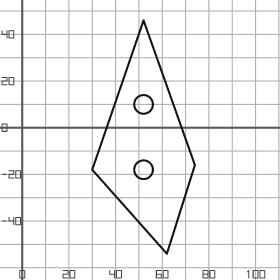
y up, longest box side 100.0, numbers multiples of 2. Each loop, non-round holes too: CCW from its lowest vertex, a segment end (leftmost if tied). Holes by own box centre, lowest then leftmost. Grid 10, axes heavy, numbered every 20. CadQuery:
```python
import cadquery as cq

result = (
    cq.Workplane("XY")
    .moveTo(62.0, -54.0)
    .lineTo(74.0, -16.0)
    .lineTo(52.0, 46.0)
    .lineTo(30.0, -18.0)
    .close()
    .moveTo(52.0, -18.0)
    .circle(4.0)
    .moveTo(52.0, 10.0)
    .circle(4.0)
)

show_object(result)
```